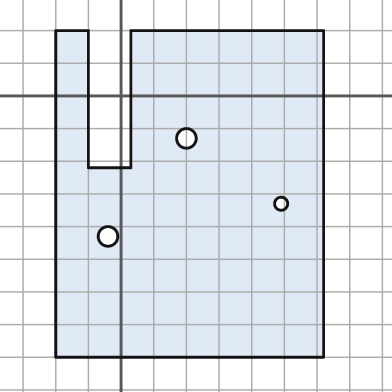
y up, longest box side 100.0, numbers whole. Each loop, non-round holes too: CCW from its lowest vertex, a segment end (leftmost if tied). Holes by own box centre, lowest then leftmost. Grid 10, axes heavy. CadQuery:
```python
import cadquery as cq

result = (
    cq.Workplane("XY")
    .moveTo(-20.0, -80.0)
    .lineTo(62.0, -80.0)
    .lineTo(62.0, 20.0)
    .lineTo(3.0, 20.0)
    .lineTo(3.0, -22.0)
    .lineTo(-10.0, -22.0)
    .lineTo(-10.0, 20.0)
    .lineTo(-20.0, 20.0)
    .close()
    .moveTo(-4.0, -43.0)
    .circle(3.0)
    .moveTo(49.0, -33.0)
    .circle(2.0)
    .moveTo(20.0, -13.0)
    .circle(3.0)
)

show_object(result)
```